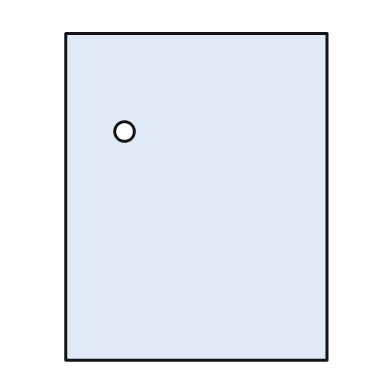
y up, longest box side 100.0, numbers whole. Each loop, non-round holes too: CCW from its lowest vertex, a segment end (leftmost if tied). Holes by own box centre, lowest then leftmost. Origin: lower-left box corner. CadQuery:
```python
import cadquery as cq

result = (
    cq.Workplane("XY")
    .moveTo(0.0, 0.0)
    .lineTo(80.0, 0.0)
    .lineTo(80.0, 100.0)
    .lineTo(0.0, 100.0)
    .close()
    .moveTo(18.0, 70.0)
    .circle(3.0)
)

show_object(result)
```